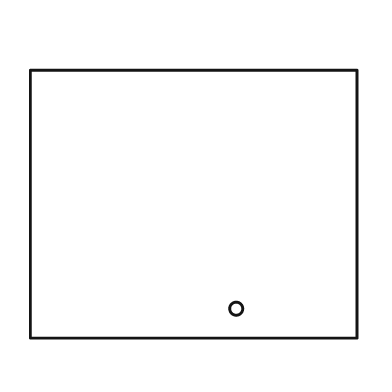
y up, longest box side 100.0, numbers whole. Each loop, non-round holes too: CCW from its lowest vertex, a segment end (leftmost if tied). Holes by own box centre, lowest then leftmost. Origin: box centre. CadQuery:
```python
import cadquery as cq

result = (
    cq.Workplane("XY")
    .moveTo(-50.0, -41.0)
    .lineTo(50.0, -41.0)
    .lineTo(50.0, 41.0)
    .lineTo(-50.0, 41.0)
    .close()
    .moveTo(13.0, -32.0)
    .circle(2.0)
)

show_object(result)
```